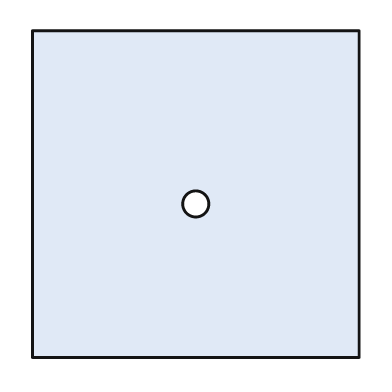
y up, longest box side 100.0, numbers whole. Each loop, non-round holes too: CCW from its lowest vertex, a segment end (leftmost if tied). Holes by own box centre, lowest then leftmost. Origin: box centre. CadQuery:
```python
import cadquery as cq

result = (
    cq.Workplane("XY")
    .moveTo(-50.0, -50.0)
    .lineTo(50.0, -50.0)
    .lineTo(50.0, 50.0)
    .lineTo(-50.0, 50.0)
    .close()
    .moveTo(0.0, -3.0)
    .circle(4.0)
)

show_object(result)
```